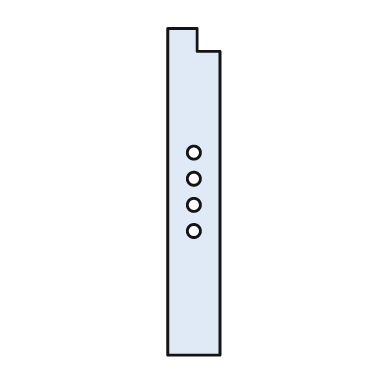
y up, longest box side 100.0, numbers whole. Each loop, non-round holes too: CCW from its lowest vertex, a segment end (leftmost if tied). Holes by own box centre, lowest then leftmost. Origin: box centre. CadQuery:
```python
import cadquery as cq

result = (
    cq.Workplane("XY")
    .moveTo(-8.0, -50.0)
    .lineTo(8.0, -50.0)
    .lineTo(8.0, 43.0)
    .lineTo(1.0, 43.0)
    .lineTo(1.0, 50.0)
    .lineTo(-8.0, 50.0)
    .close()
    .moveTo(0.0, -12.0)
    .circle(2.0)
    .moveTo(0.0, -4.0)
    .circle(2.0)
    .moveTo(0.0, 4.0)
    .circle(2.0)
    .moveTo(0.0, 12.0)
    .circle(2.0)
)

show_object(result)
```